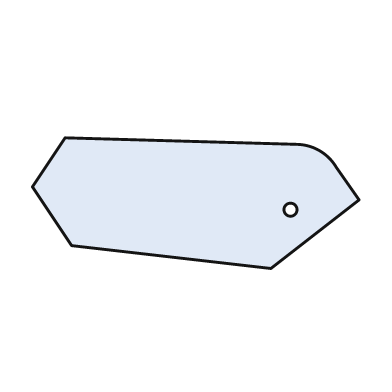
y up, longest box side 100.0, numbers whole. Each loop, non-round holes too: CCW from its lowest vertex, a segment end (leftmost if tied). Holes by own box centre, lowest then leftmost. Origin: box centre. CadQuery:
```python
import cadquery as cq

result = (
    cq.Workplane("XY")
    .moveTo(23.0, -20.0)
    .lineTo(50.0, 1.0)
    .lineTo(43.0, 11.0)
    .threePointArc((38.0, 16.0), (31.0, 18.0))
    .lineTo(-40.0, 20.0)
    .lineTo(-50.0, 5.0)
    .lineTo(-38.0, -13.0)
    .close()
    .moveTo(29.0, -2.0)
    .circle(2.0)
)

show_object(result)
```